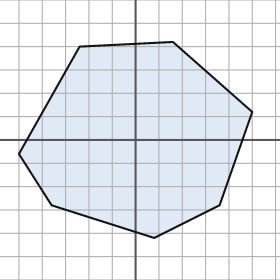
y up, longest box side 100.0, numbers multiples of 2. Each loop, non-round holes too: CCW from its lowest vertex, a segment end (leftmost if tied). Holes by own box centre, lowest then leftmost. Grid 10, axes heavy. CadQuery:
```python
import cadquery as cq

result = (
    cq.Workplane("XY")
    .moveTo(8.0, -42.0)
    .lineTo(36.0, -28.0)
    .lineTo(50.0, 12.0)
    .lineTo(16.0, 42.0)
    .lineTo(-24.0, 40.0)
    .lineTo(-50.0, -6.0)
    .lineTo(-36.0, -28.0)
    .close()
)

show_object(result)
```